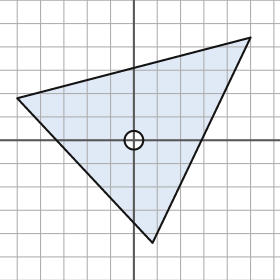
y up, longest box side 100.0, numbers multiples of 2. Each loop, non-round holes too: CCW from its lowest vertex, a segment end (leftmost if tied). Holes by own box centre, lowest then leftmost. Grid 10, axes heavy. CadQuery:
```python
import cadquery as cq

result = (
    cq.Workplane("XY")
    .moveTo(8.0, -44.0)
    .lineTo(50.0, 44.0)
    .lineTo(-50.0, 18.0)
    .close()
    .moveTo(0.0, 0.0)
    .circle(4.0)
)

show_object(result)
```